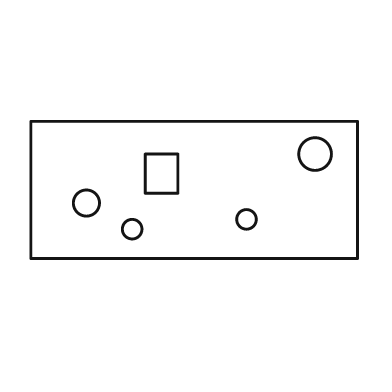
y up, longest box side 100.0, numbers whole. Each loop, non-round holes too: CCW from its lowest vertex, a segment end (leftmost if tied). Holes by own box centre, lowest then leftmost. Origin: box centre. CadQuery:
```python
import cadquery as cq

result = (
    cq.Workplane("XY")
    .moveTo(-50.0, -21.0)
    .lineTo(50.0, -21.0)
    .lineTo(50.0, 21.0)
    .lineTo(-50.0, 21.0)
    .close()
    .moveTo(-19.0, -12.0)
    .circle(3.0)
    .moveTo(16.0, -9.0)
    .circle(3.0)
    .moveTo(-33.0, -4.0)
    .circle(4.0)
    .moveTo(-15.0, -1.0)
    .lineTo(-5.0, -1.0)
    .lineTo(-5.0, 11.0)
    .lineTo(-15.0, 11.0)
    .close()
    .moveTo(37.0, 11.0)
    .circle(5.0)
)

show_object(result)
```